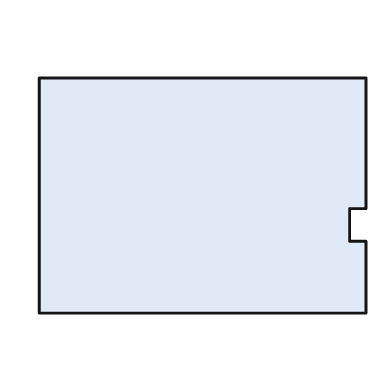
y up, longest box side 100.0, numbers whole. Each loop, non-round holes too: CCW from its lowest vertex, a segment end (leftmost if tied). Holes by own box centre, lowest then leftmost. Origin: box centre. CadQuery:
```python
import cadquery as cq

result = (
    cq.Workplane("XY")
    .moveTo(-50.0, -36.0)
    .lineTo(50.0, -36.0)
    .lineTo(50.0, -14.0)
    .lineTo(45.0, -14.0)
    .lineTo(45.0, -4.0)
    .lineTo(50.0, -4.0)
    .lineTo(50.0, 36.0)
    .lineTo(-50.0, 36.0)
    .close()
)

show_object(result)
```